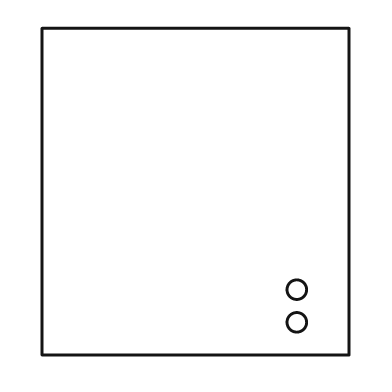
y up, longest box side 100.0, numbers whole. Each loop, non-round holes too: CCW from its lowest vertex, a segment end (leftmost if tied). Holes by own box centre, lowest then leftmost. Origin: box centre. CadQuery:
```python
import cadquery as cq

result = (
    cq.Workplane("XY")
    .moveTo(-47.0, -50.0)
    .lineTo(47.0, -50.0)
    .lineTo(47.0, 50.0)
    .lineTo(-47.0, 50.0)
    .close()
    .moveTo(31.0, -40.0)
    .circle(3.0)
    .moveTo(31.0, -30.0)
    .circle(3.0)
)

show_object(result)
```